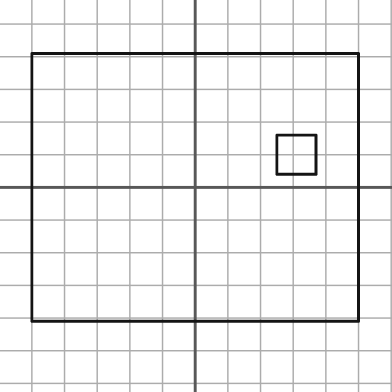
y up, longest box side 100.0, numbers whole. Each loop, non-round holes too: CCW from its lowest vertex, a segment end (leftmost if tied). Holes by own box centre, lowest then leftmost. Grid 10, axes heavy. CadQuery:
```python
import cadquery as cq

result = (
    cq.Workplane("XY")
    .moveTo(-50.0, -41.0)
    .lineTo(50.0, -41.0)
    .lineTo(50.0, 41.0)
    .lineTo(-50.0, 41.0)
    .close()
    .moveTo(25.0, 4.0)
    .lineTo(37.0, 4.0)
    .lineTo(37.0, 16.0)
    .lineTo(25.0, 16.0)
    .close()
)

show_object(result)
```